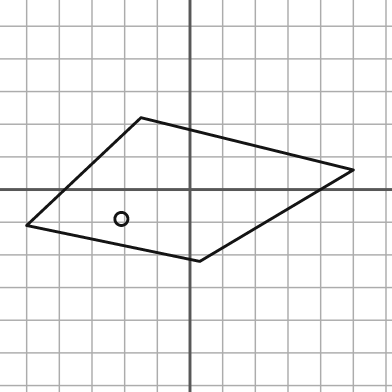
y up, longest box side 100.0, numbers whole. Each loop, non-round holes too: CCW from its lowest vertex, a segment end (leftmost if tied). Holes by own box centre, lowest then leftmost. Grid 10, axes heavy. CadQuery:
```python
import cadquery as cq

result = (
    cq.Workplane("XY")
    .moveTo(3.0, -22.0)
    .lineTo(50.0, 6.0)
    .lineTo(-15.0, 22.0)
    .lineTo(-50.0, -11.0)
    .close()
    .moveTo(-21.0, -9.0)
    .circle(2.0)
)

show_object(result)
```